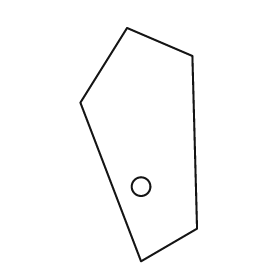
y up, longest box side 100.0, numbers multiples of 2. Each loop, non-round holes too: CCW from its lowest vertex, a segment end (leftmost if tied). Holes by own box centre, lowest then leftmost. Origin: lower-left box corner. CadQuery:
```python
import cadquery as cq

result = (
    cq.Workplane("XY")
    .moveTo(26.0, 0.0)
    .lineTo(50.0, 14.0)
    .lineTo(48.0, 88.0)
    .lineTo(20.0, 100.0)
    .lineTo(0.0, 68.0)
    .close()
    .moveTo(26.0, 32.0)
    .circle(4.0)
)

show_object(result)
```